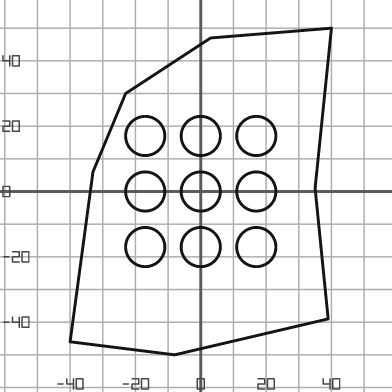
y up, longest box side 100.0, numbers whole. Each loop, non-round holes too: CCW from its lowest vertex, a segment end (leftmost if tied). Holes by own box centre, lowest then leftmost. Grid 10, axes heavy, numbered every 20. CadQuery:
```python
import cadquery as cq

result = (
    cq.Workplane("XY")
    .moveTo(-8.0, -50.0)
    .lineTo(39.0, -39.0)
    .lineTo(35.0, 1.0)
    .lineTo(40.0, 50.0)
    .lineTo(3.0, 47.0)
    .lineTo(-23.0, 30.0)
    .lineTo(-33.0, 6.0)
    .lineTo(-40.0, -46.0)
    .close()
    .moveTo(-17.0, -17.0)
    .circle(6.0)
    .moveTo(0.0, -17.0)
    .circle(6.0)
    .moveTo(17.0, -17.0)
    .circle(6.0)
    .moveTo(-17.0, 0.0)
    .circle(6.0)
    .moveTo(0.0, 0.0)
    .circle(6.0)
    .moveTo(17.0, 0.0)
    .circle(6.0)
    .moveTo(-17.0, 17.0)
    .circle(6.0)
    .moveTo(0.0, 17.0)
    .circle(6.0)
    .moveTo(17.0, 17.0)
    .circle(6.0)
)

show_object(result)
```